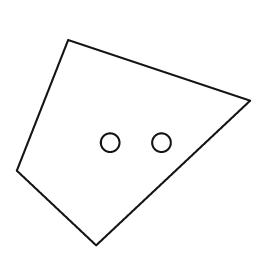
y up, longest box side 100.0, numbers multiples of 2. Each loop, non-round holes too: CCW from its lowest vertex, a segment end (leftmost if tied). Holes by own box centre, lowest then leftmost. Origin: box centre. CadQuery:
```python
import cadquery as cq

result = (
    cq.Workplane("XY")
    .moveTo(-16.0, -44.0)
    .lineTo(50.0, 18.0)
    .lineTo(-28.0, 44.0)
    .lineTo(-50.0, -12.0)
    .close()
    .moveTo(-10.0, 0.0)
    .circle(4.0)
    .moveTo(12.0, 0.0)
    .circle(4.0)
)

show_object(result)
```